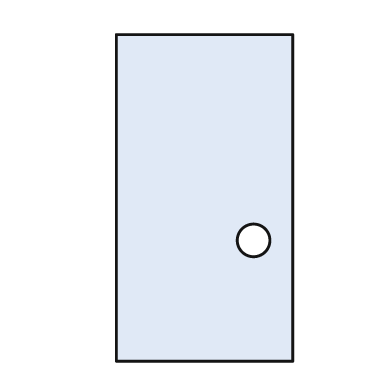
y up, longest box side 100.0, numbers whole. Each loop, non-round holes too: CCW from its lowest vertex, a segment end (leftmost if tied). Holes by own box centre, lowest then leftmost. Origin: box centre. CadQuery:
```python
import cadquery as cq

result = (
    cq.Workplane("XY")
    .moveTo(-27.0, -50.0)
    .lineTo(27.0, -50.0)
    .lineTo(27.0, 50.0)
    .lineTo(-27.0, 50.0)
    .close()
    .moveTo(15.0, -13.0)
    .circle(5.0)
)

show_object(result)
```